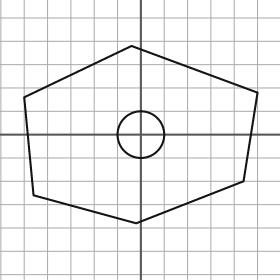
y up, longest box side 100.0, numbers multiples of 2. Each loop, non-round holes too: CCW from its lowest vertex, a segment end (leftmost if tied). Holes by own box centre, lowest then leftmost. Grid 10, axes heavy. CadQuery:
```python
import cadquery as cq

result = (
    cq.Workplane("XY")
    .moveTo(-2.0, -38.0)
    .lineTo(44.0, -20.0)
    .lineTo(50.0, 18.0)
    .lineTo(-4.0, 38.0)
    .lineTo(-50.0, 16.0)
    .lineTo(-46.0, -26.0)
    .close()
    .moveTo(0.0, 0.0)
    .circle(10.0)
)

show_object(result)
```